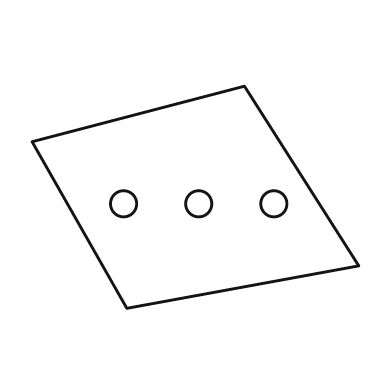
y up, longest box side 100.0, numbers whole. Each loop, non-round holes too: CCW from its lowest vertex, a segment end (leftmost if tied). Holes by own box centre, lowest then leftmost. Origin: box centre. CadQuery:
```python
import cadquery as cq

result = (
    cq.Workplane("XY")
    .moveTo(-21.0, -34.0)
    .lineTo(50.0, -21.0)
    .lineTo(15.0, 34.0)
    .lineTo(-50.0, 17.0)
    .close()
    .moveTo(-22.0, -2.0)
    .circle(4.0)
    .moveTo(1.0, -2.0)
    .circle(4.0)
    .moveTo(24.0, -2.0)
    .circle(4.0)
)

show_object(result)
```